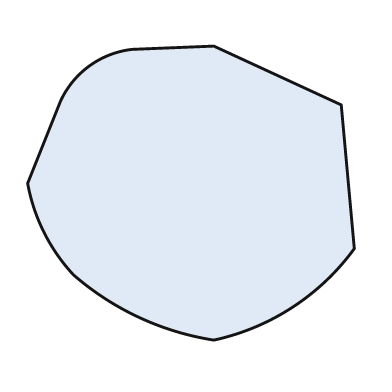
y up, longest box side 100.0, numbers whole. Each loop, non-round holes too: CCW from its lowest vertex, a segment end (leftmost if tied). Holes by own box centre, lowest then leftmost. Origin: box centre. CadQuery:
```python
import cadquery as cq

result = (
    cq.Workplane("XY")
    .moveTo(7.0, -45.0)
    .threePointArc((31.0, -35.0), (50.0, -17.0))
    .lineTo(46.0, 27.0)
    .lineTo(7.0, 45.0)
    .lineTo(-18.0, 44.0)
    .threePointArc((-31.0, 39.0), (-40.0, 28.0))
    .lineTo(-50.0, 3.0)
    .threePointArc((-45.0, -12.0), (-36.0, -25.0))
    .threePointArc((-16.0, -38.0), (7.0, -45.0))
    .close()
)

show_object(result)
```